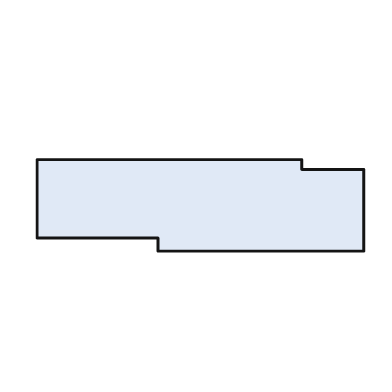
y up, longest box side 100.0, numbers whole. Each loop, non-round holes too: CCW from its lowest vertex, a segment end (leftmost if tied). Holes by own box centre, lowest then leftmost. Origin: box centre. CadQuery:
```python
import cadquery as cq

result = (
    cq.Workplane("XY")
    .moveTo(-13.0, -14.0)
    .lineTo(50.0, -14.0)
    .lineTo(50.0, 11.0)
    .lineTo(31.0, 11.0)
    .lineTo(31.0, 14.0)
    .lineTo(-50.0, 14.0)
    .lineTo(-50.0, -10.0)
    .lineTo(-13.0, -10.0)
    .close()
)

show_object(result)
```